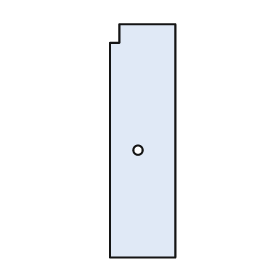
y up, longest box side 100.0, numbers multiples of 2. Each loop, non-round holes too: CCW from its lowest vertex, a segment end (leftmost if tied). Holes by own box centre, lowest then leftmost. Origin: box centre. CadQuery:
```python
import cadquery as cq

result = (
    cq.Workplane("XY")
    .moveTo(-14.0, -50.0)
    .lineTo(14.0, -50.0)
    .lineTo(14.0, 50.0)
    .lineTo(-10.0, 50.0)
    .lineTo(-10.0, 42.0)
    .lineTo(-14.0, 42.0)
    .close()
    .moveTo(-2.0, -4.0)
    .circle(2.0)
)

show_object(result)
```